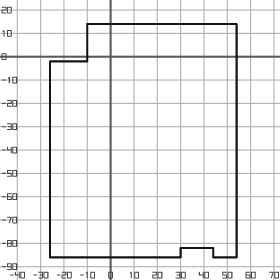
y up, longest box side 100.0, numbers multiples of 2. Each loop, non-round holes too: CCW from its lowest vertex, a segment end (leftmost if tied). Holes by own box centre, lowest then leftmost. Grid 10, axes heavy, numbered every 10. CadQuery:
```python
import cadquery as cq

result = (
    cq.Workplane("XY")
    .moveTo(-26.0, -86.0)
    .lineTo(30.0, -86.0)
    .lineTo(30.0, -82.0)
    .lineTo(44.0, -82.0)
    .lineTo(44.0, -86.0)
    .lineTo(54.0, -86.0)
    .lineTo(54.0, 14.0)
    .lineTo(-10.0, 14.0)
    .lineTo(-10.0, -2.0)
    .lineTo(-26.0, -2.0)
    .close()
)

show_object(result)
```